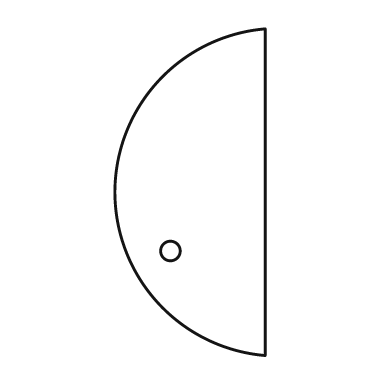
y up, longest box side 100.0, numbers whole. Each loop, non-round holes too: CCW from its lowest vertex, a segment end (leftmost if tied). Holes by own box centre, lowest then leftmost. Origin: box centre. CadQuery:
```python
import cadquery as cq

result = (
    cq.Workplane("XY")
    .moveTo(23.0, -50.0)
    .lineTo(23.0, 50.0)
    .threePointArc((-23.0, 0.0), (23.0, -50.0))
    .close()
    .moveTo(-6.0, -18.0)
    .circle(3.0)
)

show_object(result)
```